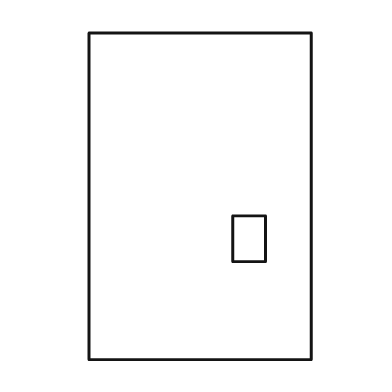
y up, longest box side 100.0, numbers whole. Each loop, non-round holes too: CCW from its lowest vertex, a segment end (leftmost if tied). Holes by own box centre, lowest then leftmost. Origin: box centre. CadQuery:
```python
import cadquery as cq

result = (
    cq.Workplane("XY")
    .moveTo(-34.0, -50.0)
    .lineTo(34.0, -50.0)
    .lineTo(34.0, 50.0)
    .lineTo(-34.0, 50.0)
    .close()
    .moveTo(10.0, -20.0)
    .lineTo(20.0, -20.0)
    .lineTo(20.0, -6.0)
    .lineTo(10.0, -6.0)
    .close()
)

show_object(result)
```